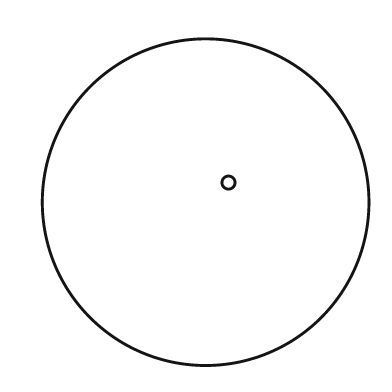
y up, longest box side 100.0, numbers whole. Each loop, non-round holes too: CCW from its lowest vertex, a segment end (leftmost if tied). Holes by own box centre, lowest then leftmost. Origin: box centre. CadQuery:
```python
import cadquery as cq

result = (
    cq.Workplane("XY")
    .moveTo(0.0, 0.0)
    .circle(50.0)
    .moveTo(7.0, 6.0)
    .circle(2.0)
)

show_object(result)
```